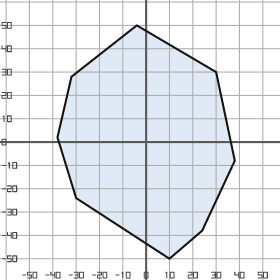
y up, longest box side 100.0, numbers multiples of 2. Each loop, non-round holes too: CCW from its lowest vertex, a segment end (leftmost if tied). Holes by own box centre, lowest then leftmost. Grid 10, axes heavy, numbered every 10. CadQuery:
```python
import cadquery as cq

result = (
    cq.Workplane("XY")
    .moveTo(10.0, -50.0)
    .lineTo(24.0, -38.0)
    .lineTo(38.0, -8.0)
    .lineTo(30.0, 30.0)
    .lineTo(-4.0, 50.0)
    .lineTo(-32.0, 28.0)
    .lineTo(-38.0, 2.0)
    .lineTo(-30.0, -24.0)
    .close()
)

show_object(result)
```